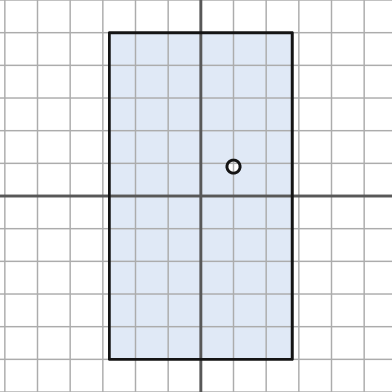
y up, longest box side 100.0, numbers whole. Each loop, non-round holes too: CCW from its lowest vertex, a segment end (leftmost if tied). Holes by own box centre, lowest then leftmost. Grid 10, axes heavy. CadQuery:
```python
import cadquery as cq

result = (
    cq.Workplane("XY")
    .moveTo(-28.0, -50.0)
    .lineTo(28.0, -50.0)
    .lineTo(28.0, 50.0)
    .lineTo(-28.0, 50.0)
    .close()
    .moveTo(10.0, 9.0)
    .circle(2.0)
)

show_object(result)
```